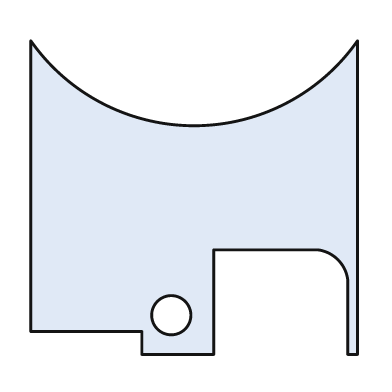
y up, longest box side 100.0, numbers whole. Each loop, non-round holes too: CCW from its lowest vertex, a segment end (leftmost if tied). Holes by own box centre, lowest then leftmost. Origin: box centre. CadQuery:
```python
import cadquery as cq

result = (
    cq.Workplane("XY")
    .moveTo(-16.0, -48.0)
    .lineTo(6.0, -48.0)
    .lineTo(6.0, -16.0)
    .lineTo(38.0, -16.0)
    .threePointArc((44.0, -19.0), (47.0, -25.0))
    .lineTo(47.0, -48.0)
    .lineTo(50.0, -48.0)
    .lineTo(50.0, 48.0)
    .threePointArc((0.0, 22.0), (-50.0, 48.0))
    .lineTo(-50.0, -41.0)
    .lineTo(-16.0, -41.0)
    .close()
    .moveTo(-7.0, -36.0)
    .circle(6.0)
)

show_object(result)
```